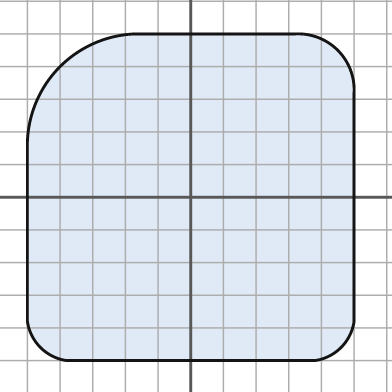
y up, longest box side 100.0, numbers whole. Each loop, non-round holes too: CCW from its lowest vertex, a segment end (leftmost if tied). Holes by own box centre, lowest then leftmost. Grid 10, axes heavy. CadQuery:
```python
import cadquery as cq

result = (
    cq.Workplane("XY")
    .moveTo(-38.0, -50.0)
    .lineTo(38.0, -50.0)
    .threePointArc((46.0, -46.0), (50.0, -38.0))
    .lineTo(50.0, 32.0)
    .threePointArc((45.0, 45.0), (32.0, 50.0))
    .lineTo(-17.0, 50.0)
    .threePointArc((-40.0, 40.0), (-50.0, 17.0))
    .lineTo(-50.0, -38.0)
    .threePointArc((-46.0, -46.0), (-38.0, -50.0))
    .close()
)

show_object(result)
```